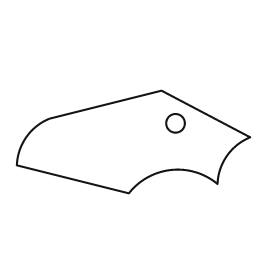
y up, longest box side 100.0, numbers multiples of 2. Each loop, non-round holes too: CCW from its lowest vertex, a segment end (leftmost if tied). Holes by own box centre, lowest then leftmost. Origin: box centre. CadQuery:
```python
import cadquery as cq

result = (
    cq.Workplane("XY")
    .moveTo(-2.0, -22.0)
    .threePointArc((16.0, -12.0), (36.0, -18.0))
    .threePointArc((40.0, -6.0), (50.0, 2.0))
    .lineTo(12.0, 22.0)
    .lineTo(-36.0, 10.0)
    .threePointArc((-46.0, 2.0), (-50.0, -10.0))
    .close()
    .moveTo(18.0, 8.0)
    .circle(4.0)
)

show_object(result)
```